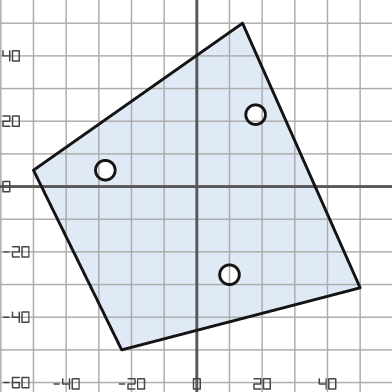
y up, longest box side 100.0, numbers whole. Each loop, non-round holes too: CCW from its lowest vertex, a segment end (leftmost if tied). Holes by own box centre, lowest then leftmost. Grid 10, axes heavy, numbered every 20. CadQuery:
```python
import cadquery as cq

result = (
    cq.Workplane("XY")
    .moveTo(-23.0, -50.0)
    .lineTo(50.0, -31.0)
    .lineTo(14.0, 50.0)
    .lineTo(-50.0, 5.0)
    .close()
    .moveTo(10.0, -27.0)
    .circle(3.0)
    .moveTo(-28.0, 5.0)
    .circle(3.0)
    .moveTo(18.0, 22.0)
    .circle(3.0)
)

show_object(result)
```